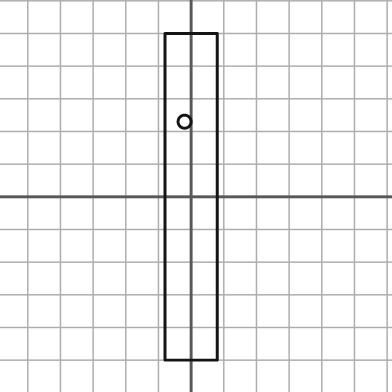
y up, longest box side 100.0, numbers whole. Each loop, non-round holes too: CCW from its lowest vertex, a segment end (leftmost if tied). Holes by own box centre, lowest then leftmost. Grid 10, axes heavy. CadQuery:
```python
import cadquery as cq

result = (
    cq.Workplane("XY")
    .moveTo(-8.0, -50.0)
    .lineTo(8.0, -50.0)
    .lineTo(8.0, 50.0)
    .lineTo(-8.0, 50.0)
    .close()
    .moveTo(-2.0, 23.0)
    .circle(2.0)
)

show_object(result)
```